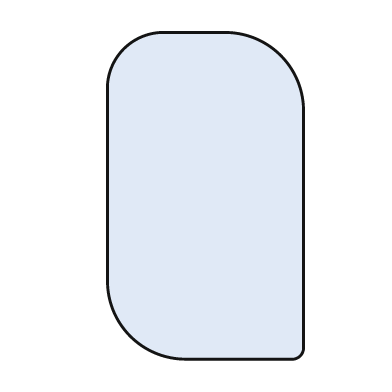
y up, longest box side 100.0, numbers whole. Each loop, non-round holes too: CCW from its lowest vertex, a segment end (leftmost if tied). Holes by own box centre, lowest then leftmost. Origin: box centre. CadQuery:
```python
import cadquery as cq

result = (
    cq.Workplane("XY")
    .moveTo(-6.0, -50.0)
    .lineTo(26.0, -50.0)
    .threePointArc((29.0, -49.0), (30.0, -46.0))
    .lineTo(30.0, 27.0)
    .threePointArc((23.0, 43.0), (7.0, 50.0))
    .lineTo(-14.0, 50.0)
    .threePointArc((-25.0, 45.0), (-30.0, 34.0))
    .lineTo(-30.0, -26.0)
    .threePointArc((-23.0, -43.0), (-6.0, -50.0))
    .close()
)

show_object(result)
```